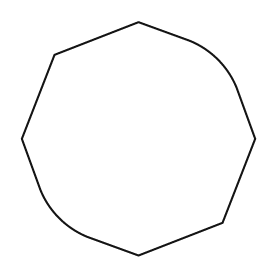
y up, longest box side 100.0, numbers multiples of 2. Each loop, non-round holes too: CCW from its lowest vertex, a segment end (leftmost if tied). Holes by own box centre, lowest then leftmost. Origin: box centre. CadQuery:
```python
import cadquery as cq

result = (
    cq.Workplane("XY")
    .moveTo(0.0, -50.0)
    .lineTo(36.0, -36.0)
    .lineTo(50.0, 0.0)
    .lineTo(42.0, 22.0)
    .threePointArc((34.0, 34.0), (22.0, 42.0))
    .lineTo(0.0, 50.0)
    .lineTo(-36.0, 36.0)
    .lineTo(-50.0, 0.0)
    .lineTo(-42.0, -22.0)
    .threePointArc((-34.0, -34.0), (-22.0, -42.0))
    .close()
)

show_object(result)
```